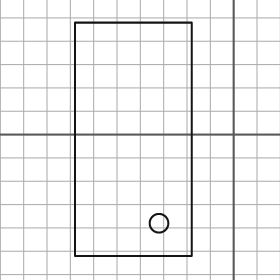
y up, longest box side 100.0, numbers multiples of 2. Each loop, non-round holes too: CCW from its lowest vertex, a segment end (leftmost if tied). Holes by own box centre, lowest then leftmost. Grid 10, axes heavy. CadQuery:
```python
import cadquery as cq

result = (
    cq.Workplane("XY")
    .moveTo(-68.0, -52.0)
    .lineTo(-18.0, -52.0)
    .lineTo(-18.0, 48.0)
    .lineTo(-68.0, 48.0)
    .close()
    .moveTo(-32.0, -38.0)
    .circle(4.0)
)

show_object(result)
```